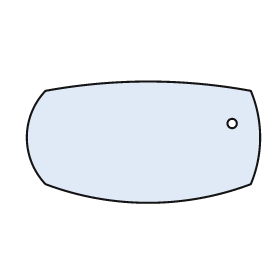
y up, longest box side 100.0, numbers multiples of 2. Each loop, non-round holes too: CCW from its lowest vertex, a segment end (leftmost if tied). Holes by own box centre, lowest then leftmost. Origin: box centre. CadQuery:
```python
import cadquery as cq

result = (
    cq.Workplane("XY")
    .moveTo(-42.0, -18.0)
    .threePointArc((2.0, -26.0), (46.0, -18.0))
    .threePointArc((50.0, 2.0), (46.0, 22.0))
    .threePointArc((2.0, 26.0), (-42.0, 22.0))
    .threePointArc((-50.0, 2.0), (-42.0, -18.0))
    .close()
    .moveTo(38.0, 8.0)
    .circle(2.0)
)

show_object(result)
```